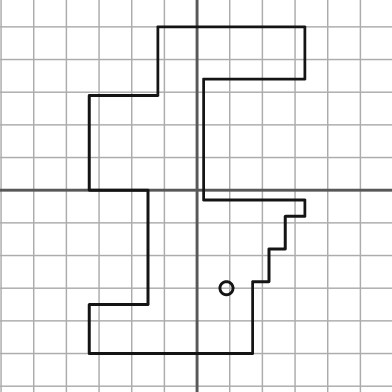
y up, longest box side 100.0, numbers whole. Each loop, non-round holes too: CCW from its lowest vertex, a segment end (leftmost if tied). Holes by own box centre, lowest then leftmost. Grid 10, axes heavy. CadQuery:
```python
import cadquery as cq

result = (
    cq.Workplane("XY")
    .moveTo(-33.0, -50.0)
    .lineTo(17.0, -50.0)
    .lineTo(17.0, -28.0)
    .lineTo(22.0, -28.0)
    .lineTo(22.0, -18.0)
    .lineTo(27.0, -18.0)
    .lineTo(27.0, -8.0)
    .lineTo(33.0, -8.0)
    .lineTo(33.0, -3.0)
    .lineTo(2.0, -3.0)
    .lineTo(2.0, 34.0)
    .lineTo(33.0, 34.0)
    .lineTo(33.0, 50.0)
    .lineTo(-12.0, 50.0)
    .lineTo(-12.0, 29.0)
    .lineTo(-33.0, 29.0)
    .lineTo(-33.0, 0.0)
    .lineTo(-15.0, 0.0)
    .lineTo(-15.0, -35.0)
    .lineTo(-33.0, -35.0)
    .close()
    .moveTo(9.0, -30.0)
    .circle(2.0)
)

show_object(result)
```